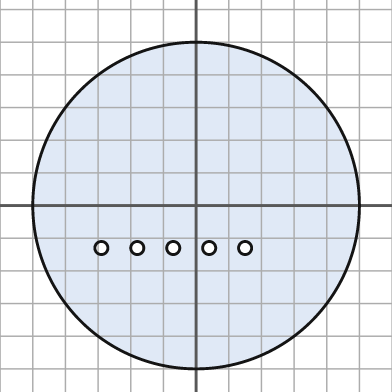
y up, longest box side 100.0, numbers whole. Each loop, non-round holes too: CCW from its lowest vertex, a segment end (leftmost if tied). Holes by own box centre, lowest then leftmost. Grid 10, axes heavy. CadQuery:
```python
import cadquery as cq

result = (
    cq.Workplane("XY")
    .moveTo(0.0, 0.0)
    .circle(50.0)
    .moveTo(-29.0, -13.0)
    .circle(2.0)
    .moveTo(-18.0, -13.0)
    .circle(2.0)
    .moveTo(-7.0, -13.0)
    .circle(2.0)
    .moveTo(4.0, -13.0)
    .circle(2.0)
    .moveTo(15.0, -13.0)
    .circle(2.0)
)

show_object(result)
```